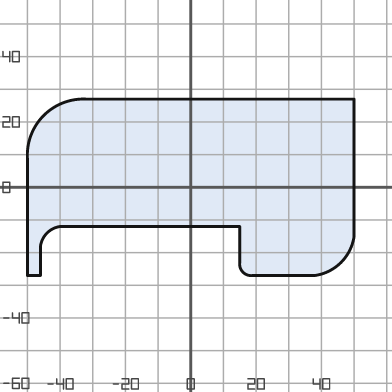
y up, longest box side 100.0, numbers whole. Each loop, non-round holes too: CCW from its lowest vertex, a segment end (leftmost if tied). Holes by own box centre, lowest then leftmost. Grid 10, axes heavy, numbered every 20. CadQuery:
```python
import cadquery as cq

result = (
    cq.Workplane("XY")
    .moveTo(-50.0, -27.0)
    .lineTo(-46.0, -27.0)
    .lineTo(-46.0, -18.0)
    .threePointArc((-44.0, -14.0), (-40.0, -12.0))
    .lineTo(15.0, -12.0)
    .lineTo(15.0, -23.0)
    .threePointArc((16.0, -26.0), (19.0, -27.0))
    .lineTo(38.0, -27.0)
    .threePointArc((46.0, -23.0), (50.0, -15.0))
    .lineTo(50.0, 27.0)
    .lineTo(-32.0, 27.0)
    .threePointArc((-45.0, 22.0), (-50.0, 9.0))
    .close()
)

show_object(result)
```